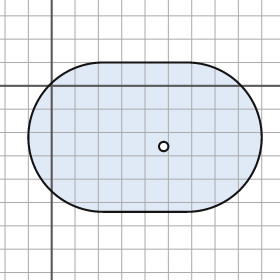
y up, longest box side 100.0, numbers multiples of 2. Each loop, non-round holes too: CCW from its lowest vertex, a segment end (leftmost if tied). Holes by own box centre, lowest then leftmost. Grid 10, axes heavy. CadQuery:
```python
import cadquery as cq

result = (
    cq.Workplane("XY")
    .moveTo(22.0, -54.0)
    .lineTo(58.0, -54.0)
    .threePointArc((90.0, -22.0), (58.0, 10.0))
    .lineTo(22.0, 10.0)
    .threePointArc((-10.0, -22.0), (22.0, -54.0))
    .close()
    .moveTo(48.0, -26.0)
    .circle(2.0)
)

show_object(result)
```